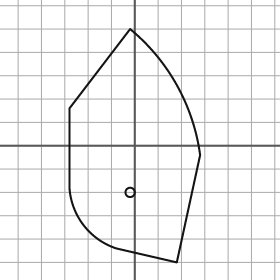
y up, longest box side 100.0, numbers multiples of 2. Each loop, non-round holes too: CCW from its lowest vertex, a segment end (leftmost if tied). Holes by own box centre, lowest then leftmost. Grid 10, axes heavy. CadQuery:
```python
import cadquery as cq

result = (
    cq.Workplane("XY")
    .moveTo(18.0, -50.0)
    .lineTo(28.0, -4.0)
    .threePointArc((18.0, 26.0), (-2.0, 50.0))
    .lineTo(-28.0, 16.0)
    .lineTo(-28.0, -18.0)
    .threePointArc((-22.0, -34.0), (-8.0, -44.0))
    .close()
    .moveTo(-2.0, -20.0)
    .circle(2.0)
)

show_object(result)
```